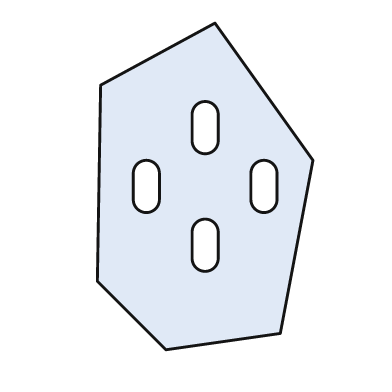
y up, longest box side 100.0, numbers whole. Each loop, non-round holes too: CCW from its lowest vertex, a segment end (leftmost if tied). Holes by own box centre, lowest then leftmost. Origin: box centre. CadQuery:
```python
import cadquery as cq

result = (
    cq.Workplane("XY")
    .moveTo(-12.0, -50.0)
    .lineTo(23.0, -45.0)
    .lineTo(33.0, 8.0)
    .lineTo(3.0, 50.0)
    .lineTo(-32.0, 31.0)
    .lineTo(-33.0, -29.0)
    .close()
    .moveTo(-4.0, -22.0)
    .threePointArc((0.0, -26.0), (4.0, -22.0))
    .lineTo(4.0, -14.0)
    .threePointArc((0.0, -10.0), (-4.0, -14.0))
    .close()
    .moveTo(-22.0, -4.0)
    .threePointArc((-18.0, -8.0), (-14.0, -4.0))
    .lineTo(-14.0, 4.0)
    .threePointArc((-18.0, 8.0), (-22.0, 4.0))
    .close()
    .moveTo(14.0, -4.0)
    .threePointArc((18.0, -8.0), (22.0, -4.0))
    .lineTo(22.0, 4.0)
    .threePointArc((18.0, 8.0), (14.0, 4.0))
    .close()
    .moveTo(-4.0, 14.0)
    .threePointArc((0.0, 10.0), (4.0, 14.0))
    .lineTo(4.0, 22.0)
    .threePointArc((0.0, 26.0), (-4.0, 22.0))
    .close()
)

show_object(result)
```